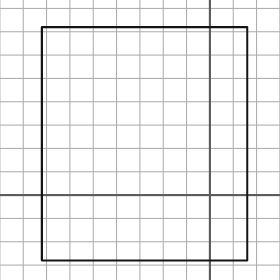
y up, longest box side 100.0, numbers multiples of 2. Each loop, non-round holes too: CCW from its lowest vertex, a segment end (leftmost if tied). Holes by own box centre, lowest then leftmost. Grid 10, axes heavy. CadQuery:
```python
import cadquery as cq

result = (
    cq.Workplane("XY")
    .moveTo(-72.0, -28.0)
    .lineTo(16.0, -28.0)
    .lineTo(16.0, 72.0)
    .lineTo(-72.0, 72.0)
    .close()
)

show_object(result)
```